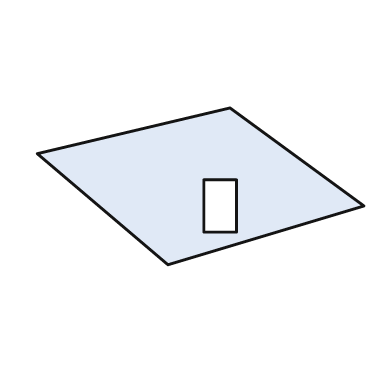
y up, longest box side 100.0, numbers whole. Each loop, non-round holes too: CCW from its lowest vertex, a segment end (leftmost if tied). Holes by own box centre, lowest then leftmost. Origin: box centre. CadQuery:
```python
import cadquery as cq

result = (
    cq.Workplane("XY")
    .moveTo(-10.0, -24.0)
    .lineTo(50.0, -6.0)
    .lineTo(9.0, 24.0)
    .lineTo(-50.0, 10.0)
    .close()
    .moveTo(1.0, -14.0)
    .lineTo(11.0, -14.0)
    .lineTo(11.0, 2.0)
    .lineTo(1.0, 2.0)
    .close()
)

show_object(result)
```